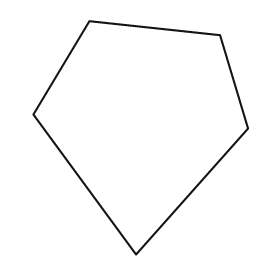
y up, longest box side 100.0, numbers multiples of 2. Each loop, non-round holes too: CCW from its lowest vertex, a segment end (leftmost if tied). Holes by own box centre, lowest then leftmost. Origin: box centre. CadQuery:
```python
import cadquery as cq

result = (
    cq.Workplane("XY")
    .moveTo(-2.0, -50.0)
    .lineTo(46.0, 4.0)
    .lineTo(34.0, 44.0)
    .lineTo(-22.0, 50.0)
    .lineTo(-46.0, 10.0)
    .close()
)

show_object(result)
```